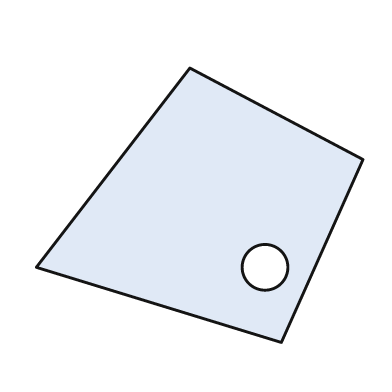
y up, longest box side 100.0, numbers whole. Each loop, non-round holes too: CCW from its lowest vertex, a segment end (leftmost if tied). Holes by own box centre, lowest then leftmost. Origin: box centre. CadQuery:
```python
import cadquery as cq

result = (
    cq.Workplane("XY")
    .moveTo(25.0, -42.0)
    .lineTo(50.0, 14.0)
    .lineTo(-3.0, 42.0)
    .lineTo(-50.0, -19.0)
    .close()
    .moveTo(20.0, -19.0)
    .circle(7.0)
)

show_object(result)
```